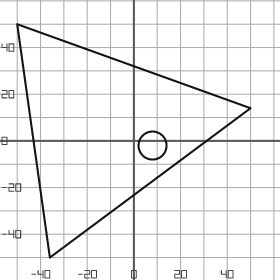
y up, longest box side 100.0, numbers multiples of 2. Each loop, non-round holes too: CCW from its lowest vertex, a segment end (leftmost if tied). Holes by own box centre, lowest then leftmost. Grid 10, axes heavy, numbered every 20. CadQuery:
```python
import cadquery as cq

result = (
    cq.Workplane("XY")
    .moveTo(-36.0, -50.0)
    .lineTo(50.0, 14.0)
    .lineTo(-50.0, 50.0)
    .close()
    .moveTo(8.0, -2.0)
    .circle(6.0)
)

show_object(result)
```